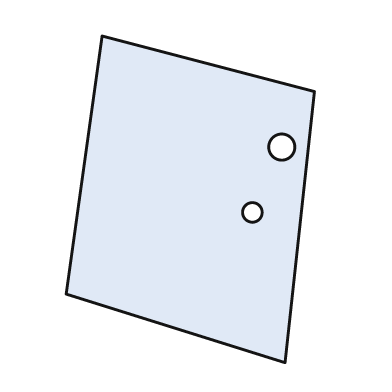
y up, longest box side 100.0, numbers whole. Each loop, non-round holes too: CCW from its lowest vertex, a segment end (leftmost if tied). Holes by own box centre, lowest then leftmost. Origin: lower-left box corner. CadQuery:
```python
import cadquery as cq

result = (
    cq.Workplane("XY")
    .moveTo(67.0, 0.0)
    .lineTo(76.0, 83.0)
    .lineTo(11.0, 100.0)
    .lineTo(0.0, 21.0)
    .close()
    .moveTo(57.0, 46.0)
    .circle(3.0)
    .moveTo(66.0, 66.0)
    .circle(4.0)
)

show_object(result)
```